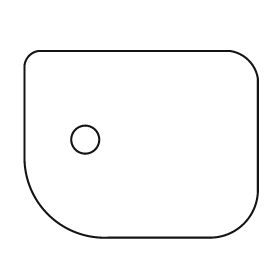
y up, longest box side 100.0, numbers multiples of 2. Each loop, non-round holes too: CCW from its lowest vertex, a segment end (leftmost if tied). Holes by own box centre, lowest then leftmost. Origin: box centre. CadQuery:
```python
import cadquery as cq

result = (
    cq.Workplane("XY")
    .moveTo(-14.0, -40.0)
    .lineTo(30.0, -40.0)
    .threePointArc((44.0, -34.0), (50.0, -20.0))
    .lineTo(50.0, 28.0)
    .threePointArc((46.0, 36.0), (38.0, 40.0))
    .lineTo(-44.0, 40.0)
    .threePointArc((-48.0, 38.0), (-50.0, 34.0))
    .lineTo(-50.0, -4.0)
    .threePointArc((-40.0, -30.0), (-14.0, -40.0))
    .close()
    .moveTo(-24.0, 2.0)
    .circle(6.0)
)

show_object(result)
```